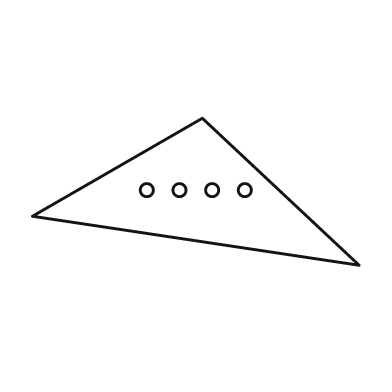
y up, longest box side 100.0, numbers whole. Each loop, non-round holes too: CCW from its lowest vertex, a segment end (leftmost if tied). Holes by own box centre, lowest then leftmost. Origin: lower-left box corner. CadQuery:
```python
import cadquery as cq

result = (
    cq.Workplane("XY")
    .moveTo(100.0, 0.0)
    .lineTo(52.0, 45.0)
    .lineTo(0.0, 15.0)
    .close()
    .moveTo(35.0, 23.0)
    .circle(2.0)
    .moveTo(45.0, 23.0)
    .circle(2.0)
    .moveTo(55.0, 23.0)
    .circle(2.0)
    .moveTo(65.0, 23.0)
    .circle(2.0)
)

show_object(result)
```